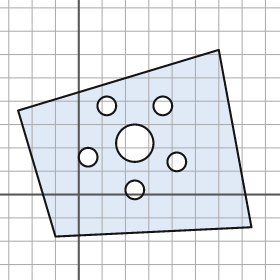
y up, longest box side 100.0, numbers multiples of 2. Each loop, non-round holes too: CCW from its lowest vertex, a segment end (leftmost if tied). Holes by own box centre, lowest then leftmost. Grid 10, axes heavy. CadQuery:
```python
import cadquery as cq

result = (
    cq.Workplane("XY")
    .moveTo(-10.0, -18.0)
    .lineTo(74.0, -14.0)
    .lineTo(60.0, 62.0)
    .lineTo(-26.0, 36.0)
    .close()
    .moveTo(24.0, 2.0)
    .circle(4.0)
    .moveTo(42.0, 14.0)
    .circle(4.0)
    .moveTo(4.0, 16.0)
    .circle(4.0)
    .moveTo(24.0, 22.0)
    .circle(8.0)
    .moveTo(12.0, 38.0)
    .circle(4.0)
    .moveTo(36.0, 38.0)
    .circle(4.0)
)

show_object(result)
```